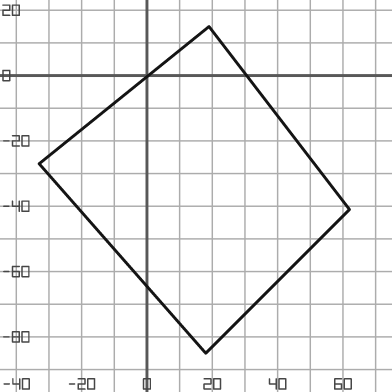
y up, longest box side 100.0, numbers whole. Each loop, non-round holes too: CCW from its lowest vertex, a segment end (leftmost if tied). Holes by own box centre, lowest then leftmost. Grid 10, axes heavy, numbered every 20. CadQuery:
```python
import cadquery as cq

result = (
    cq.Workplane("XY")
    .moveTo(18.0, -85.0)
    .lineTo(62.0, -41.0)
    .lineTo(19.0, 15.0)
    .lineTo(-33.0, -27.0)
    .close()
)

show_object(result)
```